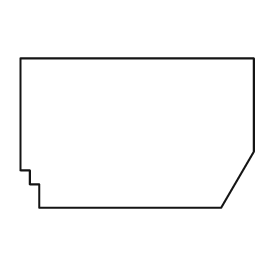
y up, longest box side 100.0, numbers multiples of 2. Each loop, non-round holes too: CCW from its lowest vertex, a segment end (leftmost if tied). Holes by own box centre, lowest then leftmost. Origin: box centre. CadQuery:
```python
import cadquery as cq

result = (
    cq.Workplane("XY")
    .moveTo(-42.0, -32.0)
    .lineTo(36.0, -32.0)
    .lineTo(50.0, -8.0)
    .lineTo(50.0, 32.0)
    .lineTo(-50.0, 32.0)
    .lineTo(-50.0, -16.0)
    .lineTo(-46.0, -16.0)
    .lineTo(-46.0, -22.0)
    .lineTo(-42.0, -22.0)
    .close()
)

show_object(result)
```